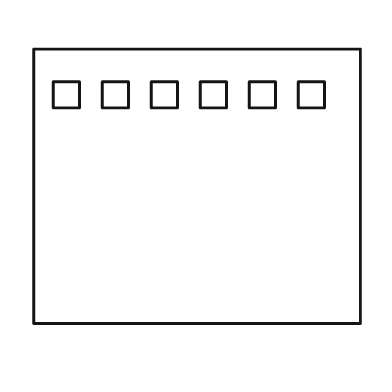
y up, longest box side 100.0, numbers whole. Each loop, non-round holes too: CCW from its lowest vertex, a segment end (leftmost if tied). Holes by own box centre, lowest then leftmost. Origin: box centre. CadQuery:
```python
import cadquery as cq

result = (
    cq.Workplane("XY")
    .moveTo(-50.0, -42.0)
    .lineTo(50.0, -42.0)
    .lineTo(50.0, 42.0)
    .lineTo(-50.0, 42.0)
    .close()
    .moveTo(-44.0, 24.0)
    .lineTo(-36.0, 24.0)
    .lineTo(-36.0, 32.0)
    .lineTo(-44.0, 32.0)
    .close()
    .moveTo(-29.0, 24.0)
    .lineTo(-21.0, 24.0)
    .lineTo(-21.0, 32.0)
    .lineTo(-29.0, 32.0)
    .close()
    .moveTo(-14.0, 24.0)
    .lineTo(-6.0, 24.0)
    .lineTo(-6.0, 32.0)
    .lineTo(-14.0, 32.0)
    .close()
    .moveTo(1.0, 24.0)
    .lineTo(9.0, 24.0)
    .lineTo(9.0, 32.0)
    .lineTo(1.0, 32.0)
    .close()
    .moveTo(16.0, 24.0)
    .lineTo(24.0, 24.0)
    .lineTo(24.0, 32.0)
    .lineTo(16.0, 32.0)
    .close()
    .moveTo(31.0, 24.0)
    .lineTo(39.0, 24.0)
    .lineTo(39.0, 32.0)
    .lineTo(31.0, 32.0)
    .close()
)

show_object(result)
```